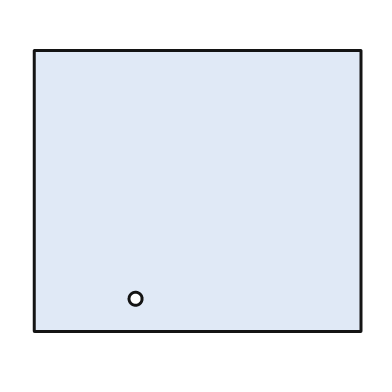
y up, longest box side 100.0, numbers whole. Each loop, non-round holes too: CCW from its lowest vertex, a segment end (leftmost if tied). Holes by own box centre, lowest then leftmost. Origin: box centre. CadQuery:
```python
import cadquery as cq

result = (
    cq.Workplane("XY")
    .moveTo(-50.0, -43.0)
    .lineTo(50.0, -43.0)
    .lineTo(50.0, 43.0)
    .lineTo(-50.0, 43.0)
    .close()
    .moveTo(-19.0, -33.0)
    .circle(2.0)
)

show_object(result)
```